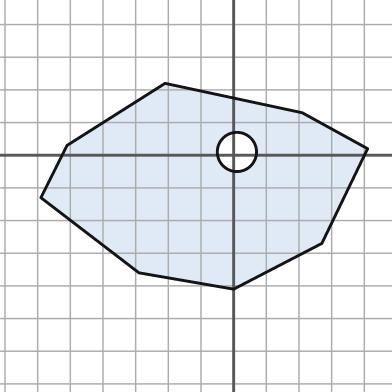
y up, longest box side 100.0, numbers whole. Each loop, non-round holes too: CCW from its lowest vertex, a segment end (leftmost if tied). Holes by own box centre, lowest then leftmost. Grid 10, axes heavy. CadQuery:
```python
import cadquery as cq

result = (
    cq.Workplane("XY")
    .moveTo(0.0, -41.0)
    .lineTo(27.0, -27.0)
    .lineTo(41.0, 2.0)
    .lineTo(21.0, 13.0)
    .lineTo(-21.0, 22.0)
    .lineTo(-51.0, 3.0)
    .lineTo(-59.0, -13.0)
    .lineTo(-29.0, -36.0)
    .close()
    .moveTo(1.0, 1.0)
    .circle(6.0)
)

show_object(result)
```